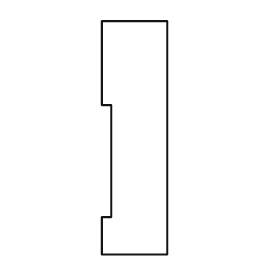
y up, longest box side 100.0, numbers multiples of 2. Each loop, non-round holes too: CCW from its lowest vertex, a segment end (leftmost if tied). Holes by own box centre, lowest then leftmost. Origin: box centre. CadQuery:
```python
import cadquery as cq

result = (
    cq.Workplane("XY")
    .moveTo(-14.0, -50.0)
    .lineTo(14.0, -50.0)
    .lineTo(14.0, 50.0)
    .lineTo(-14.0, 50.0)
    .lineTo(-14.0, 14.0)
    .lineTo(-10.0, 14.0)
    .lineTo(-10.0, -34.0)
    .lineTo(-14.0, -34.0)
    .close()
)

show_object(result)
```